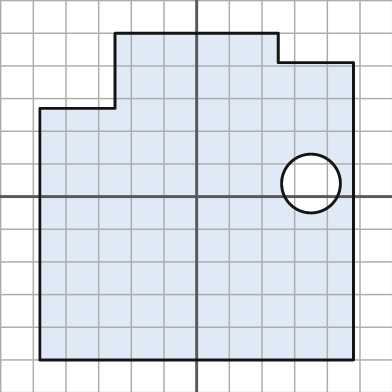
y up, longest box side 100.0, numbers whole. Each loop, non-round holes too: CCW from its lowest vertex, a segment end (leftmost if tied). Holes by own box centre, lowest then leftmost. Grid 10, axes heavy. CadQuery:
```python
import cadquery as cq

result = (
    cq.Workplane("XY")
    .moveTo(-48.0, -50.0)
    .lineTo(48.0, -50.0)
    .lineTo(48.0, 41.0)
    .lineTo(25.0, 41.0)
    .lineTo(25.0, 50.0)
    .lineTo(-25.0, 50.0)
    .lineTo(-25.0, 27.0)
    .lineTo(-48.0, 27.0)
    .close()
    .moveTo(35.0, 4.0)
    .circle(9.0)
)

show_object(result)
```